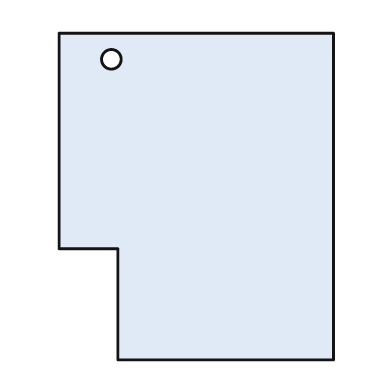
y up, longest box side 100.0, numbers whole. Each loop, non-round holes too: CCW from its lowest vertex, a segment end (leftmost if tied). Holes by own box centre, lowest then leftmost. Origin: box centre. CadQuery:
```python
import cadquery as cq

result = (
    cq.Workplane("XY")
    .moveTo(-24.0, -50.0)
    .lineTo(42.0, -50.0)
    .lineTo(42.0, 50.0)
    .lineTo(-42.0, 50.0)
    .lineTo(-42.0, -16.0)
    .lineTo(-24.0, -16.0)
    .close()
    .moveTo(-26.0, 42.0)
    .circle(3.0)
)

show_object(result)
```